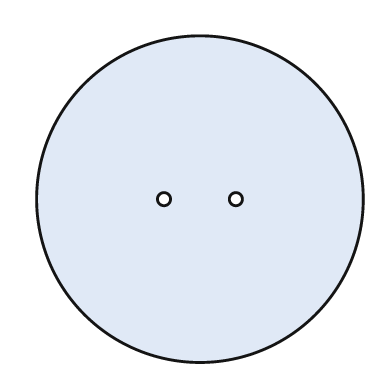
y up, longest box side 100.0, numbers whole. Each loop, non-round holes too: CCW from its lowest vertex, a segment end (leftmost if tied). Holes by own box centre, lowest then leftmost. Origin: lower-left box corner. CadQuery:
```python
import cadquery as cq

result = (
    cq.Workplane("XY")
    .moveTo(50.0, 50.0)
    .circle(50.0)
    .moveTo(39.0, 50.0)
    .circle(2.0)
    .moveTo(61.0, 50.0)
    .circle(2.0)
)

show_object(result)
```